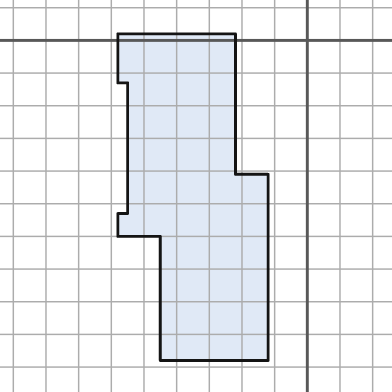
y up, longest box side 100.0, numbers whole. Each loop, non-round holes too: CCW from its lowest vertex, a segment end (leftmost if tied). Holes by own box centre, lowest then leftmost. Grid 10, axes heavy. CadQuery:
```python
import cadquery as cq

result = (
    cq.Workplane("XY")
    .moveTo(-45.0, -98.0)
    .lineTo(-12.0, -98.0)
    .lineTo(-12.0, -41.0)
    .lineTo(-22.0, -41.0)
    .lineTo(-22.0, 2.0)
    .lineTo(-58.0, 2.0)
    .lineTo(-58.0, -13.0)
    .lineTo(-55.0, -13.0)
    .lineTo(-55.0, -53.0)
    .lineTo(-58.0, -53.0)
    .lineTo(-58.0, -60.0)
    .lineTo(-45.0, -60.0)
    .close()
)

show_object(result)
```